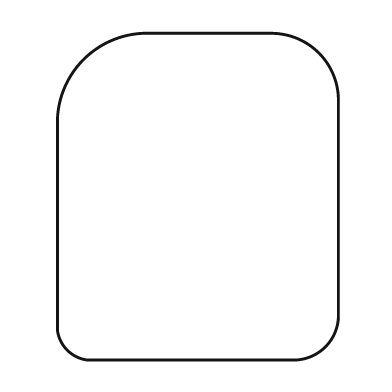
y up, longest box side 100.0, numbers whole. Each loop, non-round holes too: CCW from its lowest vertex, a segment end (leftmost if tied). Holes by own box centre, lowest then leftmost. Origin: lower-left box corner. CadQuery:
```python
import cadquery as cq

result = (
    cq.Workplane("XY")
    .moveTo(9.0, 0.0)
    .lineTo(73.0, 0.0)
    .threePointArc((82.0, 4.0), (86.0, 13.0))
    .lineTo(86.0, 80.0)
    .threePointArc((80.0, 94.0), (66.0, 100.0))
    .lineTo(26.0, 100.0)
    .threePointArc((8.0, 92.0), (0.0, 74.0))
    .lineTo(0.0, 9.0)
    .threePointArc((3.0, 3.0), (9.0, 0.0))
    .close()
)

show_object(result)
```